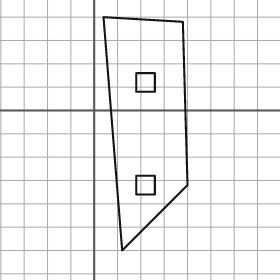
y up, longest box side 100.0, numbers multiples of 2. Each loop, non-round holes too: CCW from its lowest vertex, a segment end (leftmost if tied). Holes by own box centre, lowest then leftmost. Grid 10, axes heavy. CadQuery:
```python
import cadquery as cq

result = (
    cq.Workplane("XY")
    .moveTo(12.0, -60.0)
    .lineTo(40.0, -32.0)
    .lineTo(38.0, 38.0)
    .lineTo(4.0, 40.0)
    .close()
    .moveTo(18.0, -36.0)
    .lineTo(26.0, -36.0)
    .lineTo(26.0, -28.0)
    .lineTo(18.0, -28.0)
    .close()
    .moveTo(18.0, 8.0)
    .lineTo(26.0, 8.0)
    .lineTo(26.0, 16.0)
    .lineTo(18.0, 16.0)
    .close()
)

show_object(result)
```